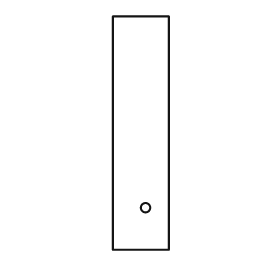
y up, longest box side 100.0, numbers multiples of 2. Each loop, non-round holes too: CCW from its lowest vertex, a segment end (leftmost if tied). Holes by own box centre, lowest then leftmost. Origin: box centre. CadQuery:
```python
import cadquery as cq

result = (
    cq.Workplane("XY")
    .moveTo(-12.0, -50.0)
    .lineTo(12.0, -50.0)
    .lineTo(12.0, 50.0)
    .lineTo(-12.0, 50.0)
    .close()
    .moveTo(2.0, -32.0)
    .circle(2.0)
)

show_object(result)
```